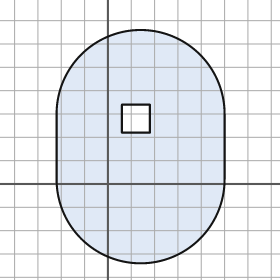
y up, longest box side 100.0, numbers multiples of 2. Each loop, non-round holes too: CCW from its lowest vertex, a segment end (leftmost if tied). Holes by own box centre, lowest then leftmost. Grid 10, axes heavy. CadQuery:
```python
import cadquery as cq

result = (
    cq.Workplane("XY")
    .moveTo(-22.0, 2.0)
    .threePointArc((14.0, -34.0), (50.0, 2.0))
    .lineTo(50.0, 30.0)
    .threePointArc((14.0, 66.0), (-22.0, 30.0))
    .close()
    .moveTo(6.0, 22.0)
    .lineTo(18.0, 22.0)
    .lineTo(18.0, 34.0)
    .lineTo(6.0, 34.0)
    .close()
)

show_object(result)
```